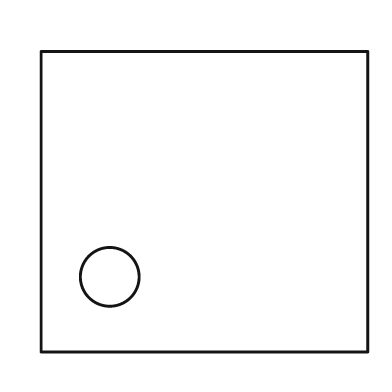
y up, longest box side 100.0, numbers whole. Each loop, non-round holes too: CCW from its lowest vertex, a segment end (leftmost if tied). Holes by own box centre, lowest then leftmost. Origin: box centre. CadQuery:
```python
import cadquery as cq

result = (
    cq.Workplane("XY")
    .moveTo(-50.0, -46.0)
    .lineTo(50.0, -46.0)
    .lineTo(50.0, 46.0)
    .lineTo(-50.0, 46.0)
    .close()
    .moveTo(-29.0, -23.0)
    .circle(9.0)
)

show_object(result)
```